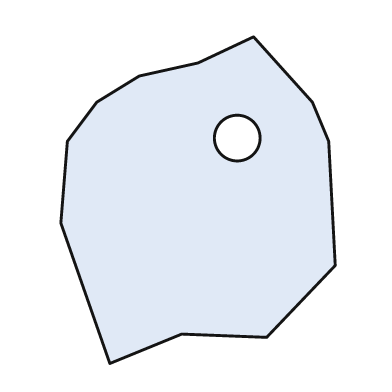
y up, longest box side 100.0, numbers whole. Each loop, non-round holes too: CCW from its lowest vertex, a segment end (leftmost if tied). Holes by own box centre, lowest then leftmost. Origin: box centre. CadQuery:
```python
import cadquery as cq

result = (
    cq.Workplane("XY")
    .moveTo(-27.0, -50.0)
    .lineTo(-5.0, -41.0)
    .lineTo(21.0, -42.0)
    .lineTo(42.0, -20.0)
    .lineTo(40.0, 18.0)
    .lineTo(35.0, 30.0)
    .lineTo(17.0, 50.0)
    .lineTo(0.0, 42.0)
    .lineTo(-18.0, 38.0)
    .lineTo(-31.0, 30.0)
    .lineTo(-40.0, 18.0)
    .lineTo(-42.0, -7.0)
    .close()
    .moveTo(12.0, 19.0)
    .circle(7.0)
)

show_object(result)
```